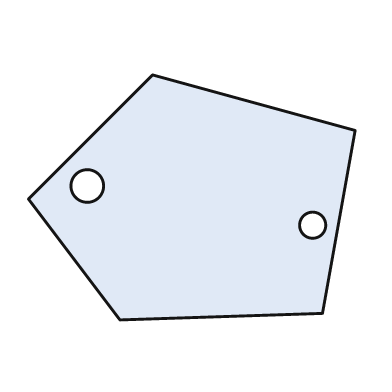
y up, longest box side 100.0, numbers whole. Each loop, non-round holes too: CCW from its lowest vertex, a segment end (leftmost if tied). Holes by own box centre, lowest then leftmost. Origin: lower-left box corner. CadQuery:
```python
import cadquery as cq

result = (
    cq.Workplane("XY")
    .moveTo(28.0, 0.0)
    .lineTo(90.0, 2.0)
    .lineTo(100.0, 58.0)
    .lineTo(38.0, 75.0)
    .lineTo(0.0, 37.0)
    .close()
    .moveTo(87.0, 29.0)
    .circle(4.0)
    .moveTo(18.0, 41.0)
    .circle(5.0)
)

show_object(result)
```